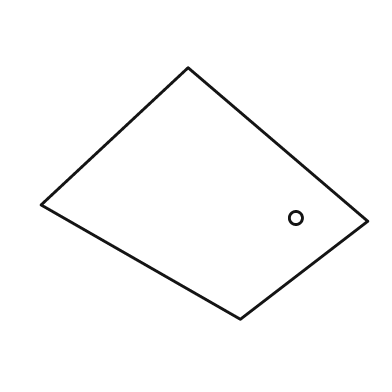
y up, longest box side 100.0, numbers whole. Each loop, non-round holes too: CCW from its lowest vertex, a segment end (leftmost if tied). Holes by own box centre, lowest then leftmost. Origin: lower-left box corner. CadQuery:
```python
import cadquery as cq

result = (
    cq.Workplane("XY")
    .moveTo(61.0, 0.0)
    .lineTo(100.0, 30.0)
    .lineTo(45.0, 77.0)
    .lineTo(0.0, 35.0)
    .close()
    .moveTo(78.0, 31.0)
    .circle(2.0)
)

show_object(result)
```